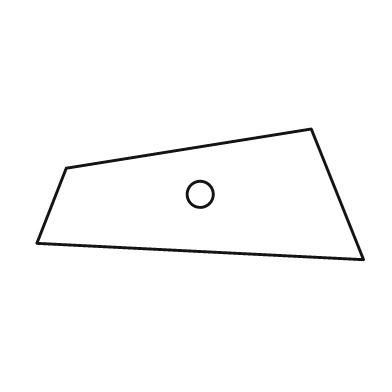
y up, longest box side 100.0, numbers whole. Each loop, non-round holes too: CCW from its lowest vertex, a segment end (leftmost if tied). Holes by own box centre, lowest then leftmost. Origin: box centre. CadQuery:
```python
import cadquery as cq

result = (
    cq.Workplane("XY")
    .moveTo(50.0, -20.0)
    .lineTo(34.0, 20.0)
    .lineTo(-41.0, 8.0)
    .lineTo(-50.0, -15.0)
    .close()
    .moveTo(0.0, 0.0)
    .circle(4.0)
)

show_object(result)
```